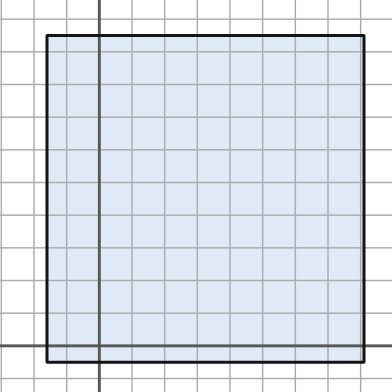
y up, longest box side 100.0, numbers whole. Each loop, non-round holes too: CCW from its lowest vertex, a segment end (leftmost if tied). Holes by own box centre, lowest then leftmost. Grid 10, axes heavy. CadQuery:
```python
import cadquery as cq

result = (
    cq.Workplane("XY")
    .moveTo(-16.0, -5.0)
    .lineTo(81.0, -5.0)
    .lineTo(81.0, 95.0)
    .lineTo(-16.0, 95.0)
    .close()
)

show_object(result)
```